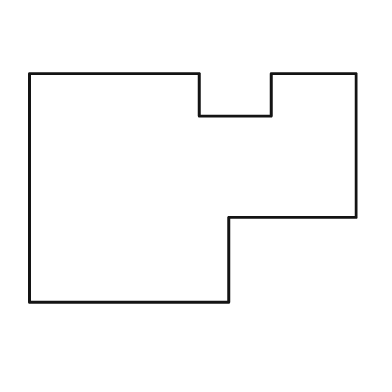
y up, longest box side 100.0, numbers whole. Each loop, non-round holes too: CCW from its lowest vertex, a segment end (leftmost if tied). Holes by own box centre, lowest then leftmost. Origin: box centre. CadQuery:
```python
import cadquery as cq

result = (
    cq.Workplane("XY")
    .moveTo(-50.0, -35.0)
    .lineTo(11.0, -35.0)
    .lineTo(11.0, -9.0)
    .lineTo(50.0, -9.0)
    .lineTo(50.0, 35.0)
    .lineTo(24.0, 35.0)
    .lineTo(24.0, 22.0)
    .lineTo(2.0, 22.0)
    .lineTo(2.0, 35.0)
    .lineTo(-50.0, 35.0)
    .close()
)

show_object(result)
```